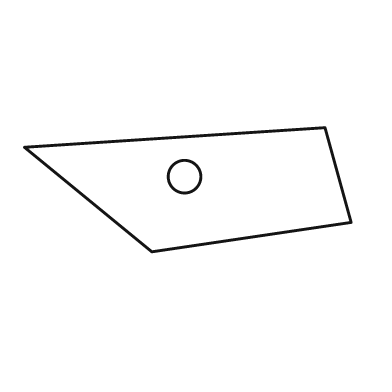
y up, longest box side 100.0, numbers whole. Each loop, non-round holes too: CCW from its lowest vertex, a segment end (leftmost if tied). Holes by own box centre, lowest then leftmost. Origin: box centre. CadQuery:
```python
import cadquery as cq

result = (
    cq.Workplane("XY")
    .moveTo(-11.0, -19.0)
    .lineTo(50.0, -10.0)
    .lineTo(42.0, 19.0)
    .lineTo(-50.0, 13.0)
    .close()
    .moveTo(-1.0, 4.0)
    .circle(5.0)
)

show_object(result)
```